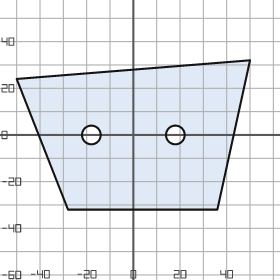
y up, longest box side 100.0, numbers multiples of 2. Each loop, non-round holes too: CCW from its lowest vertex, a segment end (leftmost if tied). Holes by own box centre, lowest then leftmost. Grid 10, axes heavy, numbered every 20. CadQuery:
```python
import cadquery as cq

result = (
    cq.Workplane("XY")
    .moveTo(-28.0, -32.0)
    .lineTo(36.0, -32.0)
    .lineTo(50.0, 32.0)
    .lineTo(-50.0, 24.0)
    .close()
    .moveTo(-18.0, 0.0)
    .circle(4.0)
    .moveTo(18.0, 0.0)
    .circle(4.0)
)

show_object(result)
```